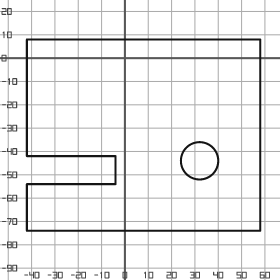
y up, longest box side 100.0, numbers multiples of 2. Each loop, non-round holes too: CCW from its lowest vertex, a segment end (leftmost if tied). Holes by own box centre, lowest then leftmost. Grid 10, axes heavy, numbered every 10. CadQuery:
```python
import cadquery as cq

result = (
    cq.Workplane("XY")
    .moveTo(-42.0, -74.0)
    .lineTo(58.0, -74.0)
    .lineTo(58.0, 8.0)
    .lineTo(-42.0, 8.0)
    .lineTo(-42.0, -42.0)
    .lineTo(-4.0, -42.0)
    .lineTo(-4.0, -54.0)
    .lineTo(-42.0, -54.0)
    .close()
    .moveTo(32.0, -44.0)
    .circle(8.0)
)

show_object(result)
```